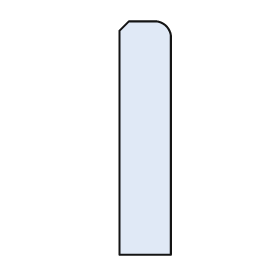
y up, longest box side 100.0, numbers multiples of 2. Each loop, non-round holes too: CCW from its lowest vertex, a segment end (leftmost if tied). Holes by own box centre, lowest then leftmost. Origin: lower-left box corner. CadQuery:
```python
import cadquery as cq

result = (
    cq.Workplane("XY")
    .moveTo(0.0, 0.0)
    .lineTo(22.0, 0.0)
    .lineTo(22.0, 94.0)
    .threePointArc((20.0, 98.0), (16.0, 100.0))
    .lineTo(4.0, 100.0)
    .lineTo(0.0, 96.0)
    .close()
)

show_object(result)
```